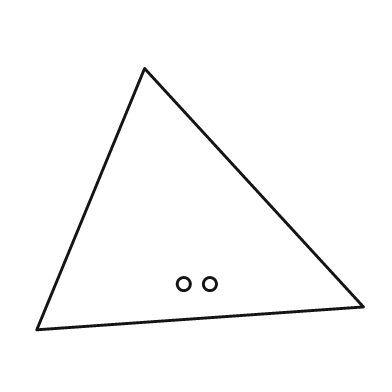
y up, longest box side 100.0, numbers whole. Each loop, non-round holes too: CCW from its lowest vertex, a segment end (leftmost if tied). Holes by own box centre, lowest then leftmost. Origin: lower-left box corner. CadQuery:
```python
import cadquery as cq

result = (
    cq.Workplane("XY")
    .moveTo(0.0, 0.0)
    .lineTo(100.0, 7.0)
    .lineTo(33.0, 80.0)
    .close()
    .moveTo(45.0, 14.0)
    .circle(2.0)
    .moveTo(53.0, 14.0)
    .circle(2.0)
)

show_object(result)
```